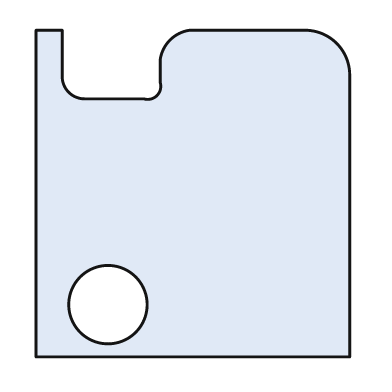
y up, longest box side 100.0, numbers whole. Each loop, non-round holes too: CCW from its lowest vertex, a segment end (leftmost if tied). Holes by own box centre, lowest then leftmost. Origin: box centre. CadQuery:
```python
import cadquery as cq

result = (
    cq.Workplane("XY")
    .moveTo(-48.0, -50.0)
    .lineTo(48.0, -50.0)
    .lineTo(48.0, 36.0)
    .threePointArc((44.0, 46.0), (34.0, 50.0))
    .lineTo(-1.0, 50.0)
    .threePointArc((-7.0, 47.0), (-10.0, 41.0))
    .lineTo(-10.0, 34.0)
    .threePointArc((-11.0, 30.0), (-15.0, 29.0))
    .lineTo(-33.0, 29.0)
    .threePointArc((-38.0, 31.0), (-40.0, 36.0))
    .lineTo(-40.0, 50.0)
    .lineTo(-48.0, 50.0)
    .close()
    .moveTo(-26.0, -34.0)
    .circle(12.0)
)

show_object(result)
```